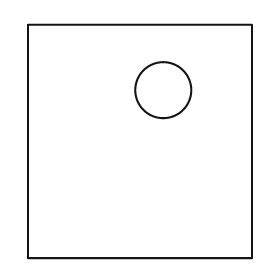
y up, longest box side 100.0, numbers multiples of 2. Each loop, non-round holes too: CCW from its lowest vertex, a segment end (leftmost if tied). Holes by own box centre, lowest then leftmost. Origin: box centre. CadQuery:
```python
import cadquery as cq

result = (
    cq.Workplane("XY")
    .moveTo(-48.0, -50.0)
    .lineTo(48.0, -50.0)
    .lineTo(48.0, 50.0)
    .lineTo(-48.0, 50.0)
    .close()
    .moveTo(10.0, 22.0)
    .circle(12.0)
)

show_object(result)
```